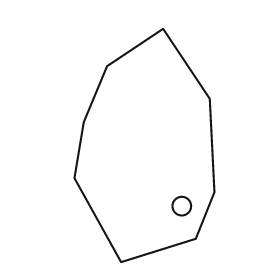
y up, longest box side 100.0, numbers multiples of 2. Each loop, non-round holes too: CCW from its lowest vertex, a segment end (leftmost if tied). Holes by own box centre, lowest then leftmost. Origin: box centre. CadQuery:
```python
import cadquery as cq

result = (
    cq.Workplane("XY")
    .moveTo(-10.0, -50.0)
    .lineTo(22.0, -40.0)
    .lineTo(30.0, -20.0)
    .lineTo(28.0, 20.0)
    .lineTo(8.0, 50.0)
    .lineTo(-16.0, 34.0)
    .lineTo(-26.0, 10.0)
    .lineTo(-30.0, -14.0)
    .close()
    .moveTo(16.0, -26.0)
    .circle(4.0)
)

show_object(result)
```